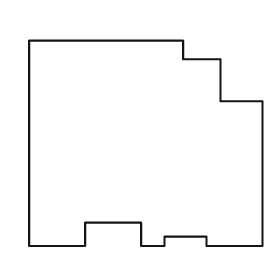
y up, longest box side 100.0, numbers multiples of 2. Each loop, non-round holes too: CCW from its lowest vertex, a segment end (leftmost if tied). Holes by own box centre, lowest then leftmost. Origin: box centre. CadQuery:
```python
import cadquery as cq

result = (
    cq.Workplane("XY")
    .moveTo(-50.0, -44.0)
    .lineTo(-26.0, -44.0)
    .lineTo(-26.0, -34.0)
    .lineTo(-2.0, -34.0)
    .lineTo(-2.0, -44.0)
    .lineTo(8.0, -44.0)
    .lineTo(8.0, -40.0)
    .lineTo(26.0, -40.0)
    .lineTo(26.0, -44.0)
    .lineTo(50.0, -44.0)
    .lineTo(50.0, 18.0)
    .lineTo(32.0, 18.0)
    .lineTo(32.0, 36.0)
    .lineTo(16.0, 36.0)
    .lineTo(16.0, 44.0)
    .lineTo(-50.0, 44.0)
    .close()
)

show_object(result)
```